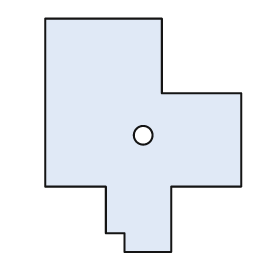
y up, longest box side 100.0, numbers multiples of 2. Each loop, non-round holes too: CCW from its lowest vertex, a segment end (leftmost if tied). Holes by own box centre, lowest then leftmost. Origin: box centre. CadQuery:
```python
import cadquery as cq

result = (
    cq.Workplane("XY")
    .moveTo(-8.0, -50.0)
    .lineTo(12.0, -50.0)
    .lineTo(12.0, -22.0)
    .lineTo(42.0, -22.0)
    .lineTo(42.0, 18.0)
    .lineTo(8.0, 18.0)
    .lineTo(8.0, 50.0)
    .lineTo(-42.0, 50.0)
    .lineTo(-42.0, -22.0)
    .lineTo(-16.0, -22.0)
    .lineTo(-16.0, -42.0)
    .lineTo(-8.0, -42.0)
    .close()
    .moveTo(0.0, 0.0)
    .circle(4.0)
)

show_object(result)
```